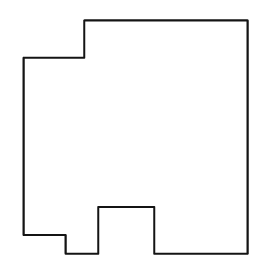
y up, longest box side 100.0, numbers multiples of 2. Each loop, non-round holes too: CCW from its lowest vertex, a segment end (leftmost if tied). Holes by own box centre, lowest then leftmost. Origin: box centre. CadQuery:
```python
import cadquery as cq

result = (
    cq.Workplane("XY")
    .moveTo(-30.0, -50.0)
    .lineTo(-16.0, -50.0)
    .lineTo(-16.0, -30.0)
    .lineTo(8.0, -30.0)
    .lineTo(8.0, -50.0)
    .lineTo(48.0, -50.0)
    .lineTo(48.0, 50.0)
    .lineTo(-22.0, 50.0)
    .lineTo(-22.0, 34.0)
    .lineTo(-48.0, 34.0)
    .lineTo(-48.0, -42.0)
    .lineTo(-30.0, -42.0)
    .close()
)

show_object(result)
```